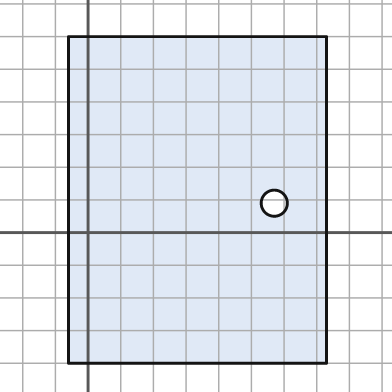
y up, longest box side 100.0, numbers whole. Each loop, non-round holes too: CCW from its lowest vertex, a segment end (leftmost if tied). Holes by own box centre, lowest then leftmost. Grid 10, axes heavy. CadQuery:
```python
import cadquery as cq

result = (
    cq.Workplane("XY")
    .moveTo(-6.0, -40.0)
    .lineTo(73.0, -40.0)
    .lineTo(73.0, 60.0)
    .lineTo(-6.0, 60.0)
    .close()
    .moveTo(57.0, 9.0)
    .circle(4.0)
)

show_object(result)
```